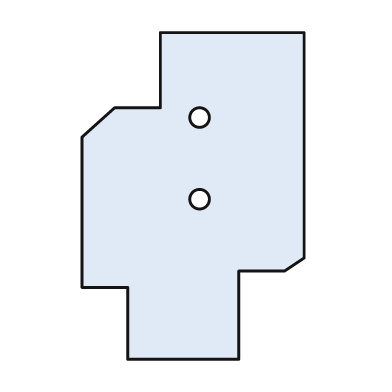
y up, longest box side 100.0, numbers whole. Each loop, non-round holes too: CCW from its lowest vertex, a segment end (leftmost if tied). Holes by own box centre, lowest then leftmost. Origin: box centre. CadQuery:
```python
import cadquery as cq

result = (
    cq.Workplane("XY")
    .moveTo(-20.0, -50.0)
    .lineTo(14.0, -50.0)
    .lineTo(14.0, -23.0)
    .lineTo(28.0, -23.0)
    .lineTo(34.0, -19.0)
    .lineTo(34.0, 50.0)
    .lineTo(-10.0, 50.0)
    .lineTo(-10.0, 27.0)
    .lineTo(-24.0, 27.0)
    .lineTo(-34.0, 18.0)
    .lineTo(-34.0, -28.0)
    .lineTo(-20.0, -28.0)
    .close()
    .moveTo(2.0, -1.0)
    .circle(3.0)
    .moveTo(2.0, 24.0)
    .circle(3.0)
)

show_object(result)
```